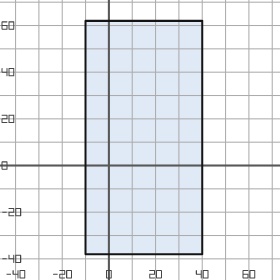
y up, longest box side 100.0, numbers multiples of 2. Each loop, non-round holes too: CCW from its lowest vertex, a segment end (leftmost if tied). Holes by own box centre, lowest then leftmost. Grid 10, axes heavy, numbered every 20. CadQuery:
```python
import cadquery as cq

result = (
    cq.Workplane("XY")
    .moveTo(-10.0, -38.0)
    .lineTo(40.0, -38.0)
    .lineTo(40.0, 62.0)
    .lineTo(-10.0, 62.0)
    .close()
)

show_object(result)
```